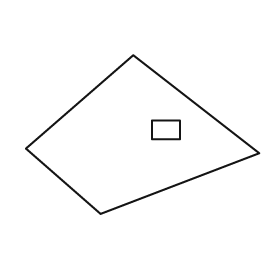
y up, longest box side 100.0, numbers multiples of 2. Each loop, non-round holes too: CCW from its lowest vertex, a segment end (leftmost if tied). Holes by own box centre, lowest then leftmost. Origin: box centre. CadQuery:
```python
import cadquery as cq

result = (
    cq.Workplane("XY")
    .moveTo(-18.0, -34.0)
    .lineTo(50.0, -8.0)
    .lineTo(-4.0, 34.0)
    .lineTo(-50.0, -6.0)
    .close()
    .moveTo(4.0, -2.0)
    .lineTo(16.0, -2.0)
    .lineTo(16.0, 6.0)
    .lineTo(4.0, 6.0)
    .close()
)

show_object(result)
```